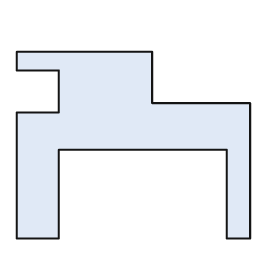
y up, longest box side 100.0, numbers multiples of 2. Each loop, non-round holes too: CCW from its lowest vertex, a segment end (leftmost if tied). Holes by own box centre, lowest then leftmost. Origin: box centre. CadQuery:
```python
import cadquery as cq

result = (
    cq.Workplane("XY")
    .moveTo(-50.0, -40.0)
    .lineTo(-32.0, -40.0)
    .lineTo(-32.0, -2.0)
    .lineTo(40.0, -2.0)
    .lineTo(40.0, -40.0)
    .lineTo(50.0, -40.0)
    .lineTo(50.0, 18.0)
    .lineTo(8.0, 18.0)
    .lineTo(8.0, 40.0)
    .lineTo(-50.0, 40.0)
    .lineTo(-50.0, 32.0)
    .lineTo(-32.0, 32.0)
    .lineTo(-32.0, 14.0)
    .lineTo(-50.0, 14.0)
    .close()
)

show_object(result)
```